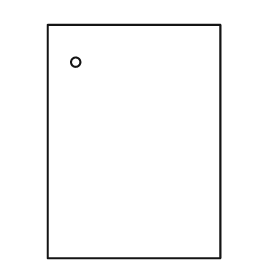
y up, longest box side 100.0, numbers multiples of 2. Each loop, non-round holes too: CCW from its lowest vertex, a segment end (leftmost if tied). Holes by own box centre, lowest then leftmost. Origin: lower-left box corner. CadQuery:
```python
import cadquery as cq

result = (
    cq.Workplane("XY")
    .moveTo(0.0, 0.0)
    .lineTo(74.0, 0.0)
    .lineTo(74.0, 100.0)
    .lineTo(0.0, 100.0)
    .close()
    .moveTo(12.0, 84.0)
    .circle(2.0)
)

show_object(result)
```